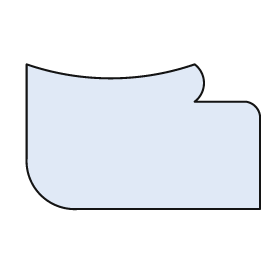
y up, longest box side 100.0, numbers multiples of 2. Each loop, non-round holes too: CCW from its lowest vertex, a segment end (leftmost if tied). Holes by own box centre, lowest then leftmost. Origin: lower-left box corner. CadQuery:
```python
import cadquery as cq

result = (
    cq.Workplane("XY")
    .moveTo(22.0, 0.0)
    .lineTo(100.0, 0.0)
    .lineTo(100.0, 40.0)
    .threePointArc((98.0, 44.0), (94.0, 46.0))
    .lineTo(72.0, 46.0)
    .threePointArc((76.0, 54.0), (72.0, 62.0))
    .threePointArc((36.0, 56.0), (0.0, 62.0))
    .lineTo(0.0, 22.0)
    .threePointArc((6.0, 6.0), (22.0, 0.0))
    .close()
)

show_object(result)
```